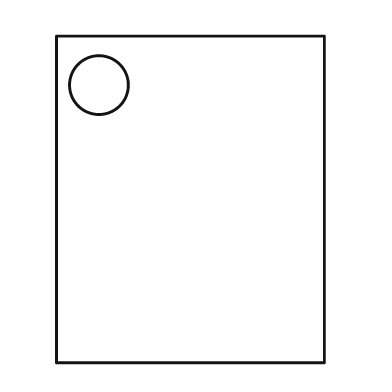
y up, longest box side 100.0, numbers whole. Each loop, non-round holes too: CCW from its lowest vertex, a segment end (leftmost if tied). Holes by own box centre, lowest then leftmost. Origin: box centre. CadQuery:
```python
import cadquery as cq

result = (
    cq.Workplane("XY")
    .moveTo(-41.0, -50.0)
    .lineTo(41.0, -50.0)
    .lineTo(41.0, 50.0)
    .lineTo(-41.0, 50.0)
    .close()
    .moveTo(-28.0, 35.0)
    .circle(9.0)
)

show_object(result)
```